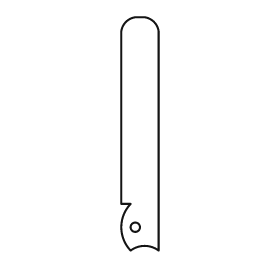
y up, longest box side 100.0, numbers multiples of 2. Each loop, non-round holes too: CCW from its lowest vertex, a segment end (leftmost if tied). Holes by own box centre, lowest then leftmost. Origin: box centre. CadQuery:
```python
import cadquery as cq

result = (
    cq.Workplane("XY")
    .moveTo(-4.0, -50.0)
    .threePointArc((2.0, -48.0), (8.0, -50.0))
    .lineTo(8.0, 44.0)
    .threePointArc((6.0, 48.0), (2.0, 50.0))
    .lineTo(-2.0, 50.0)
    .threePointArc((-6.0, 48.0), (-8.0, 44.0))
    .lineTo(-8.0, -30.0)
    .lineTo(-4.0, -30.0)
    .threePointArc((-8.0, -40.0), (-4.0, -50.0))
    .close()
    .moveTo(-2.0, -40.0)
    .circle(2.0)
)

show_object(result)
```